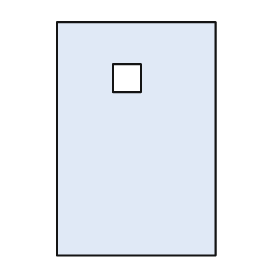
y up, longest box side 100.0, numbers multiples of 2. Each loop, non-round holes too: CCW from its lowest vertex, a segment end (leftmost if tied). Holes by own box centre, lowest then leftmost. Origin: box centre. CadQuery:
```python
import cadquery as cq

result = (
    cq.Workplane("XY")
    .moveTo(-34.0, -50.0)
    .lineTo(34.0, -50.0)
    .lineTo(34.0, 50.0)
    .lineTo(-34.0, 50.0)
    .close()
    .moveTo(-10.0, 20.0)
    .lineTo(2.0, 20.0)
    .lineTo(2.0, 32.0)
    .lineTo(-10.0, 32.0)
    .close()
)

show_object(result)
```